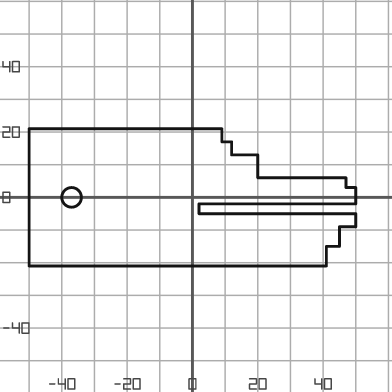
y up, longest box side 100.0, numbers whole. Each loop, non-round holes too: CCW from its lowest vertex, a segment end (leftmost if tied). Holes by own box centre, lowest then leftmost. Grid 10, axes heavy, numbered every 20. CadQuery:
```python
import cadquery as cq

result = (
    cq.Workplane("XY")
    .moveTo(-50.0, -21.0)
    .lineTo(41.0, -21.0)
    .lineTo(41.0, -15.0)
    .lineTo(45.0, -15.0)
    .lineTo(45.0, -9.0)
    .lineTo(50.0, -9.0)
    .lineTo(50.0, -5.0)
    .lineTo(2.0, -5.0)
    .lineTo(2.0, -2.0)
    .lineTo(50.0, -2.0)
    .lineTo(50.0, 3.0)
    .lineTo(47.0, 3.0)
    .lineTo(47.0, 6.0)
    .lineTo(20.0, 6.0)
    .lineTo(20.0, 13.0)
    .lineTo(12.0, 13.0)
    .lineTo(12.0, 17.0)
    .lineTo(9.0, 17.0)
    .lineTo(9.0, 21.0)
    .lineTo(-50.0, 21.0)
    .close()
    .moveTo(-37.0, 0.0)
    .circle(3.0)
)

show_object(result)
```